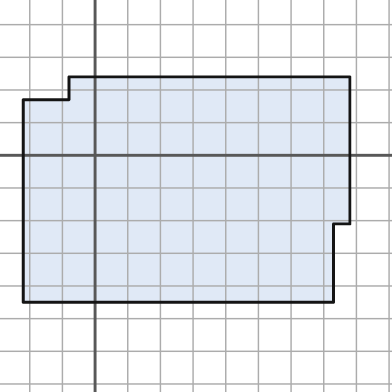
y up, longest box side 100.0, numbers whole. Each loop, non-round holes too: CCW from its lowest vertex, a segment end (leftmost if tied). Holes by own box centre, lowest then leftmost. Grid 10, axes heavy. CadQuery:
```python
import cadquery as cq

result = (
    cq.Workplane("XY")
    .moveTo(-22.0, -45.0)
    .lineTo(73.0, -45.0)
    .lineTo(73.0, -21.0)
    .lineTo(78.0, -21.0)
    .lineTo(78.0, 24.0)
    .lineTo(-8.0, 24.0)
    .lineTo(-8.0, 17.0)
    .lineTo(-22.0, 17.0)
    .close()
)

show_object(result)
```